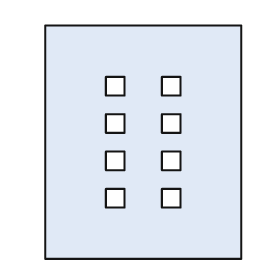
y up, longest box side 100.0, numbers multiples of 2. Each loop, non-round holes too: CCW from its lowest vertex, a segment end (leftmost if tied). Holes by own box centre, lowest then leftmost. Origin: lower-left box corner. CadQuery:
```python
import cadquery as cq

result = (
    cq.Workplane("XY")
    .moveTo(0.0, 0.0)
    .lineTo(84.0, 0.0)
    .lineTo(84.0, 100.0)
    .lineTo(0.0, 100.0)
    .close()
    .moveTo(26.0, 22.0)
    .lineTo(34.0, 22.0)
    .lineTo(34.0, 30.0)
    .lineTo(26.0, 30.0)
    .close()
    .moveTo(50.0, 22.0)
    .lineTo(58.0, 22.0)
    .lineTo(58.0, 30.0)
    .lineTo(50.0, 30.0)
    .close()
    .moveTo(26.0, 38.0)
    .lineTo(34.0, 38.0)
    .lineTo(34.0, 46.0)
    .lineTo(26.0, 46.0)
    .close()
    .moveTo(50.0, 38.0)
    .lineTo(58.0, 38.0)
    .lineTo(58.0, 46.0)
    .lineTo(50.0, 46.0)
    .close()
    .moveTo(26.0, 54.0)
    .lineTo(34.0, 54.0)
    .lineTo(34.0, 62.0)
    .lineTo(26.0, 62.0)
    .close()
    .moveTo(50.0, 54.0)
    .lineTo(58.0, 54.0)
    .lineTo(58.0, 62.0)
    .lineTo(50.0, 62.0)
    .close()
    .moveTo(26.0, 70.0)
    .lineTo(34.0, 70.0)
    .lineTo(34.0, 78.0)
    .lineTo(26.0, 78.0)
    .close()
    .moveTo(50.0, 70.0)
    .lineTo(58.0, 70.0)
    .lineTo(58.0, 78.0)
    .lineTo(50.0, 78.0)
    .close()
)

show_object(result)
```